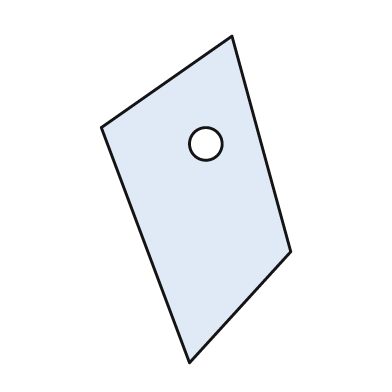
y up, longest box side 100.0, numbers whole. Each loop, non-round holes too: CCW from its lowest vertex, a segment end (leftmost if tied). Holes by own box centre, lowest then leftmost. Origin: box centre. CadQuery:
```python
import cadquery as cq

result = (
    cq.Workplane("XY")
    .moveTo(-2.0, -50.0)
    .lineTo(29.0, -16.0)
    .lineTo(11.0, 50.0)
    .lineTo(-29.0, 22.0)
    .close()
    .moveTo(3.0, 17.0)
    .circle(5.0)
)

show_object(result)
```